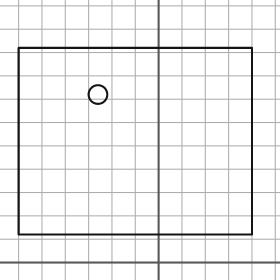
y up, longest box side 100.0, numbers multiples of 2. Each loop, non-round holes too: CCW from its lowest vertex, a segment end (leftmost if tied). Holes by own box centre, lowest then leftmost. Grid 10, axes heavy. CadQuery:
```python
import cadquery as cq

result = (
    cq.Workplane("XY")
    .moveTo(-60.0, 12.0)
    .lineTo(40.0, 12.0)
    .lineTo(40.0, 92.0)
    .lineTo(-60.0, 92.0)
    .close()
    .moveTo(-26.0, 72.0)
    .circle(4.0)
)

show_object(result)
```